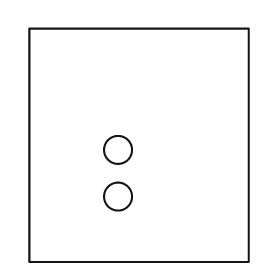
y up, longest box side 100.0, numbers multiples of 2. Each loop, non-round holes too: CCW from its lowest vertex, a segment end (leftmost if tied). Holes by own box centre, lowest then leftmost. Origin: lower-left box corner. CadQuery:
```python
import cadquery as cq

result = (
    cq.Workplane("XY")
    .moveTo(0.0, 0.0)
    .lineTo(94.0, 0.0)
    .lineTo(94.0, 100.0)
    .lineTo(0.0, 100.0)
    .close()
    .moveTo(38.0, 28.0)
    .circle(6.0)
    .moveTo(38.0, 48.0)
    .circle(6.0)
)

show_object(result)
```